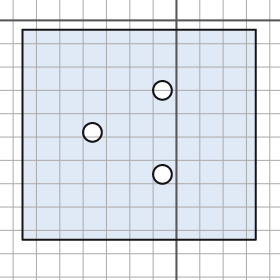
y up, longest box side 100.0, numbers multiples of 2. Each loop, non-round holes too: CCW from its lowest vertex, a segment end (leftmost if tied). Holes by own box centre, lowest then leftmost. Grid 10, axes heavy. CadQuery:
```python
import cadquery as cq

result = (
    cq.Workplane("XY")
    .moveTo(-66.0, -94.0)
    .lineTo(34.0, -94.0)
    .lineTo(34.0, -4.0)
    .lineTo(-66.0, -4.0)
    .close()
    .moveTo(-6.0, -66.0)
    .circle(4.0)
    .moveTo(-36.0, -48.0)
    .circle(4.0)
    .moveTo(-6.0, -30.0)
    .circle(4.0)
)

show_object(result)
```